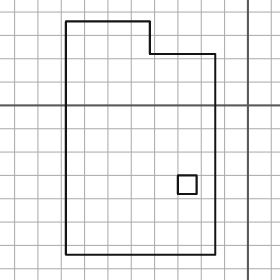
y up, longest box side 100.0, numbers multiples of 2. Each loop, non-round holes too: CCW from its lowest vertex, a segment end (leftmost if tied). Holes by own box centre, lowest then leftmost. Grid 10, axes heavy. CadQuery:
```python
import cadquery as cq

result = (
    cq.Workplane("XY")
    .moveTo(-78.0, -64.0)
    .lineTo(-14.0, -64.0)
    .lineTo(-14.0, 22.0)
    .lineTo(-42.0, 22.0)
    .lineTo(-42.0, 36.0)
    .lineTo(-78.0, 36.0)
    .close()
    .moveTo(-30.0, -38.0)
    .lineTo(-22.0, -38.0)
    .lineTo(-22.0, -30.0)
    .lineTo(-30.0, -30.0)
    .close()
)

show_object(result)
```